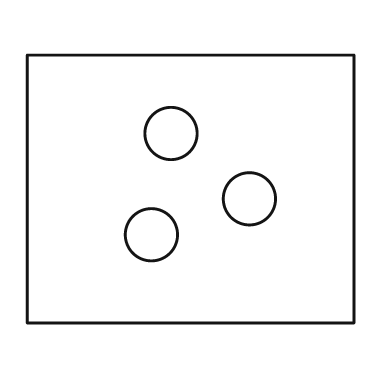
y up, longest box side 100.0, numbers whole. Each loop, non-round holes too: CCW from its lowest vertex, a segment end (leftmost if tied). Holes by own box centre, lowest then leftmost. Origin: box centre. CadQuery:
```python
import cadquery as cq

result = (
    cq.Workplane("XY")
    .moveTo(-50.0, -41.0)
    .lineTo(50.0, -41.0)
    .lineTo(50.0, 41.0)
    .lineTo(-50.0, 41.0)
    .close()
    .moveTo(-12.0, -14.0)
    .circle(8.0)
    .moveTo(18.0, -3.0)
    .circle(8.0)
    .moveTo(-6.0, 17.0)
    .circle(8.0)
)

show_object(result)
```